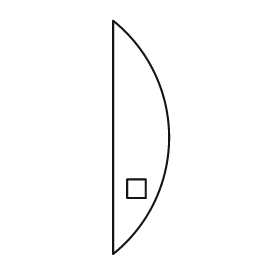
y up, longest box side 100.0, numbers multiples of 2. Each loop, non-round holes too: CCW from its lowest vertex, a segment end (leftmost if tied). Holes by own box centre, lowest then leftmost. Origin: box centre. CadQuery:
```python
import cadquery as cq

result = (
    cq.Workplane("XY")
    .moveTo(-12.0, -50.0)
    .threePointArc((12.0, 0.0), (-12.0, 50.0))
    .close()
    .moveTo(-6.0, -26.0)
    .lineTo(2.0, -26.0)
    .lineTo(2.0, -18.0)
    .lineTo(-6.0, -18.0)
    .close()
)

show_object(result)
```